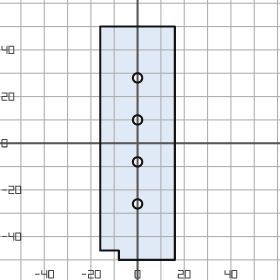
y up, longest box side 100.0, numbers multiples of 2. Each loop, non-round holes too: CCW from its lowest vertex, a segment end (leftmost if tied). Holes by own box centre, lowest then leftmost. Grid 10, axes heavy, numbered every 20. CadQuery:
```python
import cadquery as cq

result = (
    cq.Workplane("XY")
    .moveTo(-8.0, -50.0)
    .lineTo(16.0, -50.0)
    .lineTo(16.0, 50.0)
    .lineTo(-16.0, 50.0)
    .lineTo(-16.0, -46.0)
    .lineTo(-8.0, -46.0)
    .close()
    .moveTo(0.0, -26.0)
    .circle(2.0)
    .moveTo(0.0, -8.0)
    .circle(2.0)
    .moveTo(0.0, 10.0)
    .circle(2.0)
    .moveTo(0.0, 28.0)
    .circle(2.0)
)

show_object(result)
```